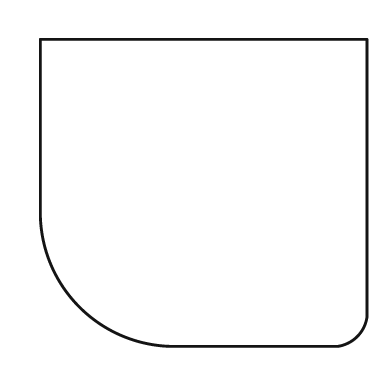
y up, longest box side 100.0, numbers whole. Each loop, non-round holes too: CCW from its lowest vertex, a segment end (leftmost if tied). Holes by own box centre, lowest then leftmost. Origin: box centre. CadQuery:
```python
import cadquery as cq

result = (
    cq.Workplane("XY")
    .moveTo(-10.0, -47.0)
    .lineTo(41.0, -47.0)
    .threePointArc((47.0, -44.0), (50.0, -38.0))
    .lineTo(50.0, 47.0)
    .lineTo(-50.0, 47.0)
    .lineTo(-50.0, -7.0)
    .threePointArc((-38.0, -35.0), (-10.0, -47.0))
    .close()
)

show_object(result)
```